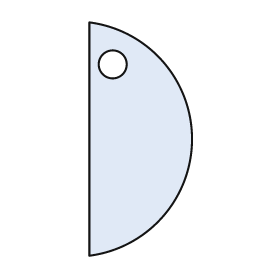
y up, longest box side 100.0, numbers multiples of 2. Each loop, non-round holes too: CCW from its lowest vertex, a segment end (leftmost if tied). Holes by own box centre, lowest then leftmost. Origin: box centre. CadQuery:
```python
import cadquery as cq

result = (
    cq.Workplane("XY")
    .moveTo(-22.0, -50.0)
    .threePointArc((22.0, 0.0), (-22.0, 50.0))
    .close()
    .moveTo(-12.0, 32.0)
    .circle(6.0)
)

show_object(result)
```